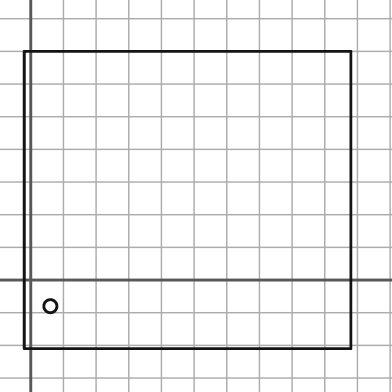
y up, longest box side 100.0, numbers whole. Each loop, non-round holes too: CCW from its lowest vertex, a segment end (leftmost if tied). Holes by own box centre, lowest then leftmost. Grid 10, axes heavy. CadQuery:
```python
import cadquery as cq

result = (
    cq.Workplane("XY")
    .moveTo(-2.0, -21.0)
    .lineTo(98.0, -21.0)
    .lineTo(98.0, 70.0)
    .lineTo(-2.0, 70.0)
    .close()
    .moveTo(6.0, -8.0)
    .circle(2.0)
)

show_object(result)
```